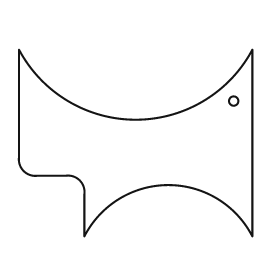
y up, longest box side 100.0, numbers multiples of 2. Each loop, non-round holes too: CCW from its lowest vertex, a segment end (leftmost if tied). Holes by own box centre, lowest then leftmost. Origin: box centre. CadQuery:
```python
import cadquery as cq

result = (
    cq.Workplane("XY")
    .moveTo(-22.0, -40.0)
    .threePointArc((14.0, -18.0), (50.0, -40.0))
    .lineTo(50.0, 40.0)
    .threePointArc((0.0, 10.0), (-50.0, 40.0))
    .lineTo(-50.0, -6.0)
    .threePointArc((-48.0, -12.0), (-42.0, -14.0))
    .lineTo(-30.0, -14.0)
    .threePointArc((-24.0, -16.0), (-22.0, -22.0))
    .close()
    .moveTo(42.0, 18.0)
    .circle(2.0)
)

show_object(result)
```